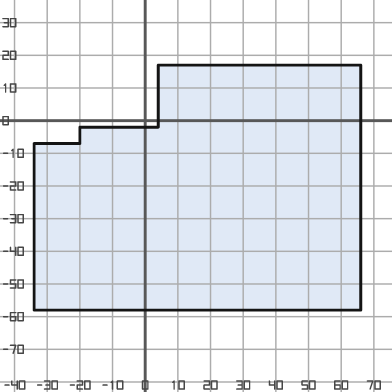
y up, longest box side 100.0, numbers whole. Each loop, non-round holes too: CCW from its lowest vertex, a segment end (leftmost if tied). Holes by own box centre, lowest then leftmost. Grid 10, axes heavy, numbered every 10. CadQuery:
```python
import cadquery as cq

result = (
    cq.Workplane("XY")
    .moveTo(-34.0, -58.0)
    .lineTo(66.0, -58.0)
    .lineTo(66.0, 17.0)
    .lineTo(4.0, 17.0)
    .lineTo(4.0, -2.0)
    .lineTo(-20.0, -2.0)
    .lineTo(-20.0, -7.0)
    .lineTo(-34.0, -7.0)
    .close()
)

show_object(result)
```